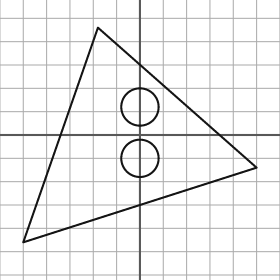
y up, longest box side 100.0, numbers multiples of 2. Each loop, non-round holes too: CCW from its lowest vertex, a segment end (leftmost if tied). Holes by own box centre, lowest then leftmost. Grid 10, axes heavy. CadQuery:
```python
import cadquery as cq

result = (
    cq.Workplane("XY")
    .moveTo(-50.0, -46.0)
    .lineTo(50.0, -14.0)
    .lineTo(-18.0, 46.0)
    .close()
    .moveTo(0.0, -10.0)
    .circle(8.0)
    .moveTo(0.0, 12.0)
    .circle(8.0)
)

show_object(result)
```